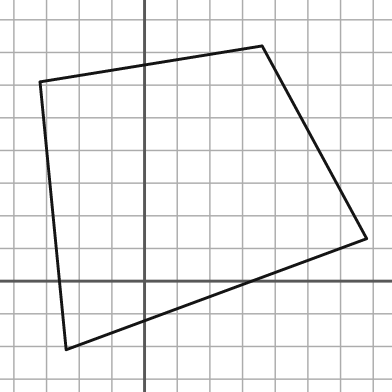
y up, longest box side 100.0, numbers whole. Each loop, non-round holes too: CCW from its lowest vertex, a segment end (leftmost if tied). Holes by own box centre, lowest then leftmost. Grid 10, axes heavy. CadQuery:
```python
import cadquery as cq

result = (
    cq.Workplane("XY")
    .moveTo(-24.0, -21.0)
    .lineTo(68.0, 13.0)
    .lineTo(36.0, 72.0)
    .lineTo(-32.0, 61.0)
    .close()
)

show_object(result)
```